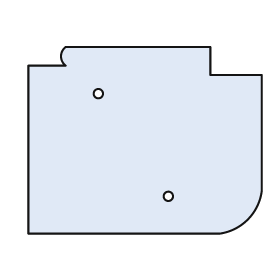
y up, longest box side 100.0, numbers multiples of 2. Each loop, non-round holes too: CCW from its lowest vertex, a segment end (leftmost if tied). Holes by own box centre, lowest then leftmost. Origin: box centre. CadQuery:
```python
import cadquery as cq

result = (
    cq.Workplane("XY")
    .moveTo(-50.0, -40.0)
    .lineTo(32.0, -40.0)
    .threePointArc((44.0, -34.0), (50.0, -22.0))
    .lineTo(50.0, 28.0)
    .lineTo(28.0, 28.0)
    .lineTo(28.0, 40.0)
    .lineTo(-34.0, 40.0)
    .threePointArc((-36.0, 36.0), (-34.0, 32.0))
    .lineTo(-50.0, 32.0)
    .close()
    .moveTo(10.0, -24.0)
    .circle(2.0)
    .moveTo(-20.0, 20.0)
    .circle(2.0)
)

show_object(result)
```